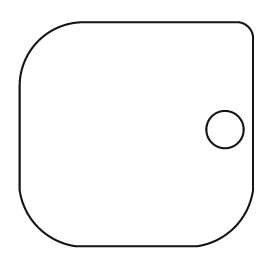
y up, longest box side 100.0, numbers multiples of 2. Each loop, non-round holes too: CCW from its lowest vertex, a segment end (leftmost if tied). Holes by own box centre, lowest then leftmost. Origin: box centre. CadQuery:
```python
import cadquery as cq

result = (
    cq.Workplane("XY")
    .moveTo(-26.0, -48.0)
    .lineTo(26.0, -48.0)
    .threePointArc((42.0, -40.0), (50.0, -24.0))
    .lineTo(50.0, 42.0)
    .threePointArc((48.0, 46.0), (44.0, 48.0))
    .lineTo(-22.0, 48.0)
    .threePointArc((-42.0, 40.0), (-50.0, 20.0))
    .lineTo(-50.0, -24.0)
    .threePointArc((-42.0, -40.0), (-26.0, -48.0))
    .close()
    .moveTo(38.0, 2.0)
    .circle(8.0)
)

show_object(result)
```